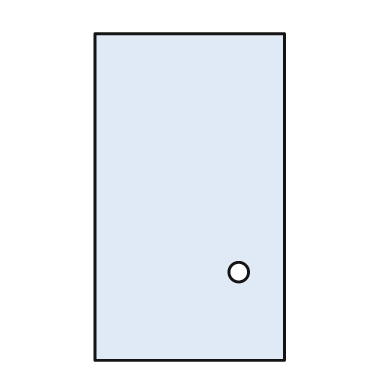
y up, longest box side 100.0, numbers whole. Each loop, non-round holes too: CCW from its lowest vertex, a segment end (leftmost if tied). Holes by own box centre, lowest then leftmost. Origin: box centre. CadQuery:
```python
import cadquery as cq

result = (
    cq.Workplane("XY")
    .moveTo(-29.0, -50.0)
    .lineTo(29.0, -50.0)
    .lineTo(29.0, 50.0)
    .lineTo(-29.0, 50.0)
    .close()
    .moveTo(15.0, -23.0)
    .circle(3.0)
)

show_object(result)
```